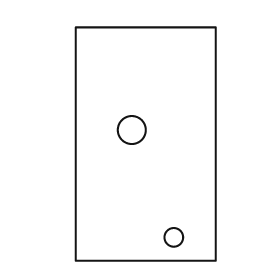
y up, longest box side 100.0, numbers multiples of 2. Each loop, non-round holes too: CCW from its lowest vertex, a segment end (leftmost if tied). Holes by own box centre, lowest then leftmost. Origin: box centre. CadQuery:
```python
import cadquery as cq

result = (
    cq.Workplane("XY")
    .moveTo(-30.0, -50.0)
    .lineTo(30.0, -50.0)
    .lineTo(30.0, 50.0)
    .lineTo(-30.0, 50.0)
    .close()
    .moveTo(12.0, -40.0)
    .circle(4.0)
    .moveTo(-6.0, 6.0)
    .circle(6.0)
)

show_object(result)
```